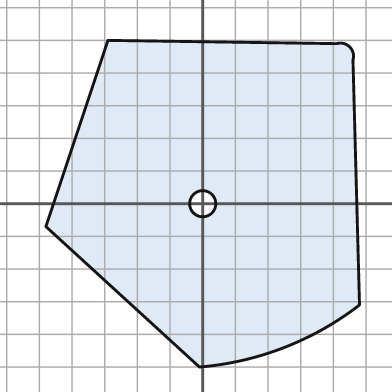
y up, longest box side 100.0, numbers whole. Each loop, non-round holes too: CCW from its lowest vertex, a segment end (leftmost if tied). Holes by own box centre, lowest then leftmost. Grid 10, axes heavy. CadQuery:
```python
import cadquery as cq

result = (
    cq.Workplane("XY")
    .moveTo(-1.0, -50.0)
    .threePointArc((25.0, -44.0), (48.0, -31.0))
    .lineTo(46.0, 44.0)
    .threePointArc((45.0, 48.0), (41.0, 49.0))
    .lineTo(-29.0, 50.0)
    .lineTo(-48.0, -7.0)
    .close()
    .moveTo(0.0, 0.0)
    .circle(4.0)
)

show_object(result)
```